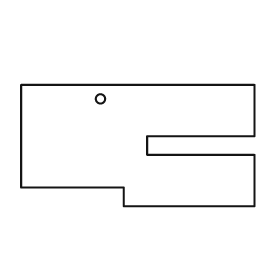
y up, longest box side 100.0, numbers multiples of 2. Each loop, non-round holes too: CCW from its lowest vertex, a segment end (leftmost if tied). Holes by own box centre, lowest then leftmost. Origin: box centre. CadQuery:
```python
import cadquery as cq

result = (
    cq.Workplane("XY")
    .moveTo(-6.0, -26.0)
    .lineTo(50.0, -26.0)
    .lineTo(50.0, -4.0)
    .lineTo(4.0, -4.0)
    .lineTo(4.0, 4.0)
    .lineTo(50.0, 4.0)
    .lineTo(50.0, 26.0)
    .lineTo(-50.0, 26.0)
    .lineTo(-50.0, -18.0)
    .lineTo(-6.0, -18.0)
    .close()
    .moveTo(-16.0, 20.0)
    .circle(2.0)
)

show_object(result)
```